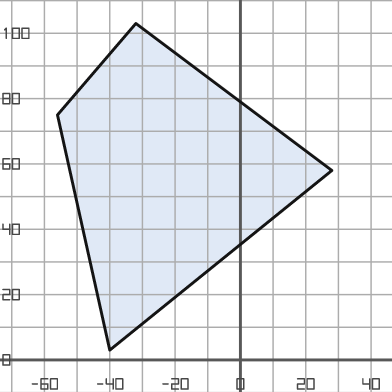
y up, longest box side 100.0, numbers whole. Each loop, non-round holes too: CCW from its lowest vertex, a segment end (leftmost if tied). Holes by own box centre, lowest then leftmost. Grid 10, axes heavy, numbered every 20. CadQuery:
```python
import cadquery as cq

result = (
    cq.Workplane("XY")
    .moveTo(-40.0, 3.0)
    .lineTo(28.0, 58.0)
    .lineTo(-32.0, 103.0)
    .lineTo(-56.0, 75.0)
    .close()
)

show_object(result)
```